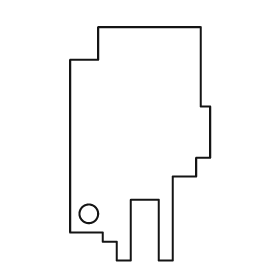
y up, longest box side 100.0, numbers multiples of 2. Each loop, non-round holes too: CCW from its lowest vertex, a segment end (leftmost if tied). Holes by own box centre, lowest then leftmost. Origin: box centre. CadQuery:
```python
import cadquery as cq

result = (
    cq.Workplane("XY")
    .moveTo(-10.0, -50.0)
    .lineTo(-4.0, -50.0)
    .lineTo(-4.0, -24.0)
    .lineTo(8.0, -24.0)
    .lineTo(8.0, -50.0)
    .lineTo(14.0, -50.0)
    .lineTo(14.0, -14.0)
    .lineTo(24.0, -14.0)
    .lineTo(24.0, -6.0)
    .lineTo(30.0, -6.0)
    .lineTo(30.0, 16.0)
    .lineTo(26.0, 16.0)
    .lineTo(26.0, 50.0)
    .lineTo(-18.0, 50.0)
    .lineTo(-18.0, 36.0)
    .lineTo(-30.0, 36.0)
    .lineTo(-30.0, -38.0)
    .lineTo(-16.0, -38.0)
    .lineTo(-16.0, -42.0)
    .lineTo(-10.0, -42.0)
    .close()
    .moveTo(-22.0, -30.0)
    .circle(4.0)
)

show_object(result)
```